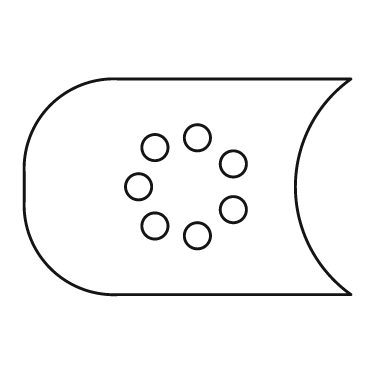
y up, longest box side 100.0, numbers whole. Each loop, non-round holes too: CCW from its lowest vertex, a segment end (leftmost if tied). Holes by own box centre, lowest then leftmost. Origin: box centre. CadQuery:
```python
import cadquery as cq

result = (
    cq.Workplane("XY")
    .moveTo(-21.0, -33.0)
    .lineTo(50.0, -33.0)
    .threePointArc((33.0, 0.0), (50.0, 33.0))
    .lineTo(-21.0, 33.0)
    .threePointArc((-42.0, 25.0), (-50.0, 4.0))
    .lineTo(-50.0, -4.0)
    .threePointArc((-42.0, -25.0), (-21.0, -33.0))
    .close()
    .moveTo(3.0, -15.0)
    .circle(4.0)
    .moveTo(-10.0, -12.0)
    .circle(4.0)
    .moveTo(14.0, -7.0)
    .circle(4.0)
    .moveTo(-15.0, 0.0)
    .circle(4.0)
    .moveTo(14.0, 7.0)
    .circle(4.0)
    .moveTo(-10.0, 12.0)
    .circle(4.0)
    .moveTo(3.0, 15.0)
    .circle(4.0)
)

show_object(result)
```